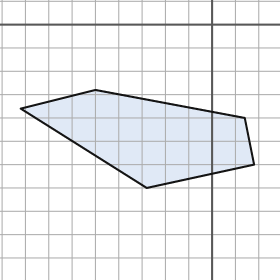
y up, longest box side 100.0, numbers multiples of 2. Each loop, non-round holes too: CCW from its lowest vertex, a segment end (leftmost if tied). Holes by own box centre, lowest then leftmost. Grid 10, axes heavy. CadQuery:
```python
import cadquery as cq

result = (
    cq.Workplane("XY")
    .moveTo(-28.0, -70.0)
    .lineTo(18.0, -60.0)
    .lineTo(14.0, -40.0)
    .lineTo(-50.0, -28.0)
    .lineTo(-82.0, -36.0)
    .close()
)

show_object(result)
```